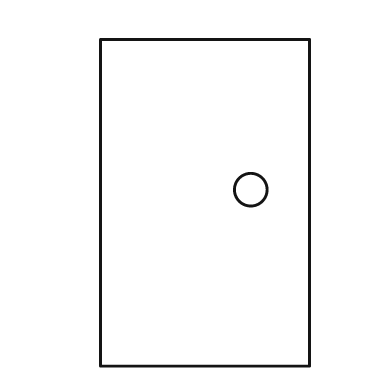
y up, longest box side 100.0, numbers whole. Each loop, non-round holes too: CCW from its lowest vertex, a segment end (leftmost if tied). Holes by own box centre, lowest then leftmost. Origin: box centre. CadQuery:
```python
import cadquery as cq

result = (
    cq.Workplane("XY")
    .moveTo(-32.0, -50.0)
    .lineTo(32.0, -50.0)
    .lineTo(32.0, 50.0)
    .lineTo(-32.0, 50.0)
    .close()
    .moveTo(14.0, 4.0)
    .circle(5.0)
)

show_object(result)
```